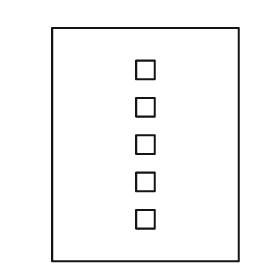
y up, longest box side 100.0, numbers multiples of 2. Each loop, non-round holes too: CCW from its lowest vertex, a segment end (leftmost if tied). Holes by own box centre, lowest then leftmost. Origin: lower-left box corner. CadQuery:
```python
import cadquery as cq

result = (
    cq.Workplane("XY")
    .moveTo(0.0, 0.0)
    .lineTo(80.0, 0.0)
    .lineTo(80.0, 100.0)
    .lineTo(0.0, 100.0)
    .close()
    .moveTo(36.0, 14.0)
    .lineTo(44.0, 14.0)
    .lineTo(44.0, 22.0)
    .lineTo(36.0, 22.0)
    .close()
    .moveTo(36.0, 30.0)
    .lineTo(44.0, 30.0)
    .lineTo(44.0, 38.0)
    .lineTo(36.0, 38.0)
    .close()
    .moveTo(36.0, 46.0)
    .lineTo(44.0, 46.0)
    .lineTo(44.0, 54.0)
    .lineTo(36.0, 54.0)
    .close()
    .moveTo(36.0, 62.0)
    .lineTo(44.0, 62.0)
    .lineTo(44.0, 70.0)
    .lineTo(36.0, 70.0)
    .close()
    .moveTo(36.0, 78.0)
    .lineTo(44.0, 78.0)
    .lineTo(44.0, 86.0)
    .lineTo(36.0, 86.0)
    .close()
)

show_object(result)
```